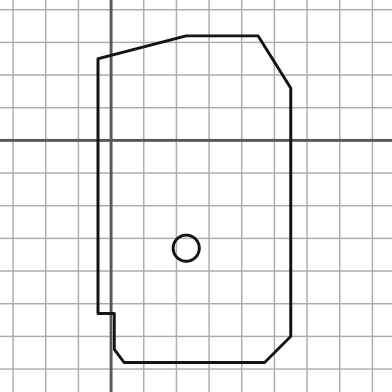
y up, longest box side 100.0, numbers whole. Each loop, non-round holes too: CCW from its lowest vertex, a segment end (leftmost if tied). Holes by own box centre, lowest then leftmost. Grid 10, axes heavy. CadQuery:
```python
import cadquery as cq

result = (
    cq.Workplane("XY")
    .moveTo(4.0, -68.0)
    .lineTo(47.0, -68.0)
    .lineTo(55.0, -60.0)
    .lineTo(55.0, 16.0)
    .lineTo(45.0, 32.0)
    .lineTo(23.0, 32.0)
    .lineTo(-4.0, 25.0)
    .lineTo(-4.0, -53.0)
    .lineTo(1.0, -53.0)
    .lineTo(1.0, -64.0)
    .close()
    .moveTo(23.0, -33.0)
    .circle(4.0)
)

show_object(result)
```